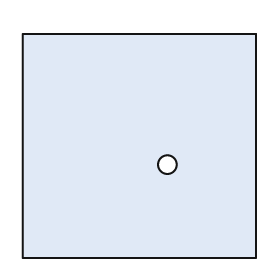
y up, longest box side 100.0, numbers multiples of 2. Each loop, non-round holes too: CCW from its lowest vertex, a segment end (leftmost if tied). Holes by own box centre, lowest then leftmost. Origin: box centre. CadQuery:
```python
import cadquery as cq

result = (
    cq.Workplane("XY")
    .moveTo(-50.0, -48.0)
    .lineTo(50.0, -48.0)
    .lineTo(50.0, 48.0)
    .lineTo(-50.0, 48.0)
    .close()
    .moveTo(12.0, -8.0)
    .circle(4.0)
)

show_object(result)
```